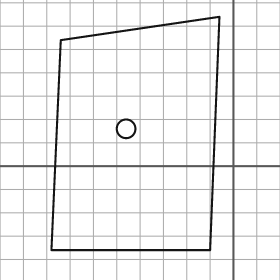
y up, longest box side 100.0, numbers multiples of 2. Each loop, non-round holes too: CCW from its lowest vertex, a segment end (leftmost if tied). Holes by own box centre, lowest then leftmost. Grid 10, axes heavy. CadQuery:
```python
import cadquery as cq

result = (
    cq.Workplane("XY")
    .moveTo(-78.0, -36.0)
    .lineTo(-10.0, -36.0)
    .lineTo(-6.0, 64.0)
    .lineTo(-74.0, 54.0)
    .close()
    .moveTo(-46.0, 16.0)
    .circle(4.0)
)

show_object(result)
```